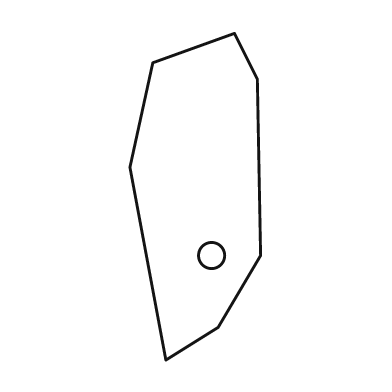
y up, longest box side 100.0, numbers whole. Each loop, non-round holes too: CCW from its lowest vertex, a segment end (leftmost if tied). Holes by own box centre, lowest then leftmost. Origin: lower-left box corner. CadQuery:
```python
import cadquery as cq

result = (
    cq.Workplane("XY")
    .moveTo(11.0, 0.0)
    .lineTo(27.0, 10.0)
    .lineTo(40.0, 32.0)
    .lineTo(39.0, 86.0)
    .lineTo(32.0, 100.0)
    .lineTo(7.0, 91.0)
    .lineTo(0.0, 59.0)
    .close()
    .moveTo(25.0, 32.0)
    .circle(4.0)
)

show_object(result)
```